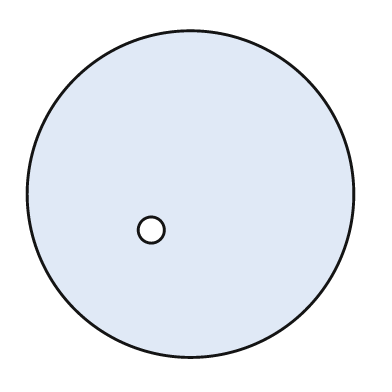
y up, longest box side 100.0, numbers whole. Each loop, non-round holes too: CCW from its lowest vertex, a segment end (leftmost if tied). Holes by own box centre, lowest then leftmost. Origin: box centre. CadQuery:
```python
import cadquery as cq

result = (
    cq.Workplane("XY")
    .moveTo(0.0, 0.0)
    .circle(50.0)
    .moveTo(-12.0, -11.0)
    .circle(4.0)
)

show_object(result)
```